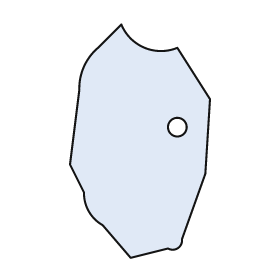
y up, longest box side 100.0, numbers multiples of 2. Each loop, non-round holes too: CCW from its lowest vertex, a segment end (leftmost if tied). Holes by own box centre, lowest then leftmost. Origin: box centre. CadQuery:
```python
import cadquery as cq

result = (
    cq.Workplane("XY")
    .moveTo(-4.0, -50.0)
    .lineTo(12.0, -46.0)
    .threePointArc((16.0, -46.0), (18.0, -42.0))
    .lineTo(28.0, -14.0)
    .lineTo(30.0, 18.0)
    .lineTo(16.0, 40.0)
    .threePointArc((2.0, 40.0), (-8.0, 50.0))
    .lineTo(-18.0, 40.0)
    .threePointArc((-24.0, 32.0), (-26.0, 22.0))
    .lineTo(-30.0, -10.0)
    .lineTo(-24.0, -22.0)
    .threePointArc((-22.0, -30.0), (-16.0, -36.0))
    .close()
    .moveTo(16.0, 6.0)
    .circle(4.0)
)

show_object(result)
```